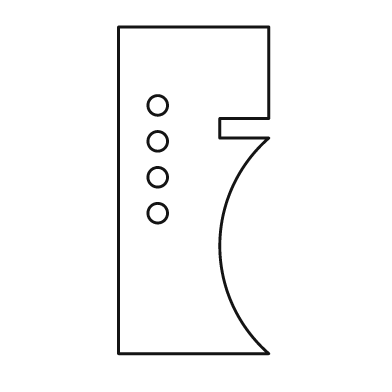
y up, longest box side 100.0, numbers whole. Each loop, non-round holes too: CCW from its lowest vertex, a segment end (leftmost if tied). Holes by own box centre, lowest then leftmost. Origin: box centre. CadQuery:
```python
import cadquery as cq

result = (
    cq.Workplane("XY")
    .moveTo(-23.0, -50.0)
    .lineTo(23.0, -50.0)
    .threePointArc((8.0, -17.0), (23.0, 16.0))
    .lineTo(8.0, 16.0)
    .lineTo(8.0, 22.0)
    .lineTo(23.0, 22.0)
    .lineTo(23.0, 50.0)
    .lineTo(-23.0, 50.0)
    .close()
    .moveTo(-11.0, -7.0)
    .circle(3.0)
    .moveTo(-11.0, 4.0)
    .circle(3.0)
    .moveTo(-11.0, 15.0)
    .circle(3.0)
    .moveTo(-11.0, 26.0)
    .circle(3.0)
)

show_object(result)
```